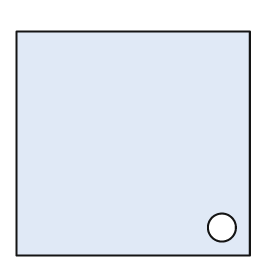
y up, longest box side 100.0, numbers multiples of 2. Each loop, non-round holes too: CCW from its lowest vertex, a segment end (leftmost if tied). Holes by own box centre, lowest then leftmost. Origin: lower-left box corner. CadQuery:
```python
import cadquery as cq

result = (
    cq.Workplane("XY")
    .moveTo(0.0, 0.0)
    .lineTo(100.0, 0.0)
    .lineTo(100.0, 96.0)
    .lineTo(0.0, 96.0)
    .close()
    .moveTo(88.0, 12.0)
    .circle(6.0)
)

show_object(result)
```